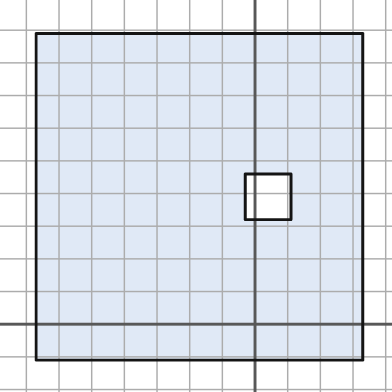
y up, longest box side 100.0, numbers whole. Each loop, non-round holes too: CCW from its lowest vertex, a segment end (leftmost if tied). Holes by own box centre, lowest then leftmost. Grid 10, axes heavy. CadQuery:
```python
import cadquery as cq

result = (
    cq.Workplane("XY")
    .moveTo(-67.0, -11.0)
    .lineTo(33.0, -11.0)
    .lineTo(33.0, 89.0)
    .lineTo(-67.0, 89.0)
    .close()
    .moveTo(-3.0, 32.0)
    .lineTo(11.0, 32.0)
    .lineTo(11.0, 46.0)
    .lineTo(-3.0, 46.0)
    .close()
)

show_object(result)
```